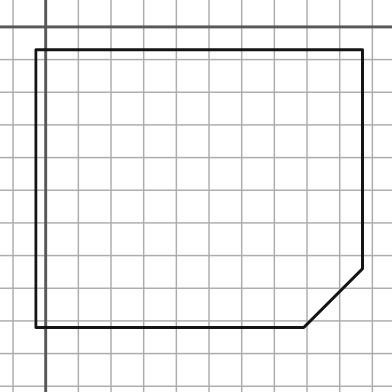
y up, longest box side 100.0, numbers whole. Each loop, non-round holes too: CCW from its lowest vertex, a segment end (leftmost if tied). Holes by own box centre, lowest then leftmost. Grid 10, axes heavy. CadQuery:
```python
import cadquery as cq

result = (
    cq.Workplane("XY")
    .moveTo(-3.0, -92.0)
    .lineTo(79.0, -92.0)
    .lineTo(97.0, -74.0)
    .lineTo(97.0, -7.0)
    .lineTo(-3.0, -7.0)
    .close()
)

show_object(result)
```